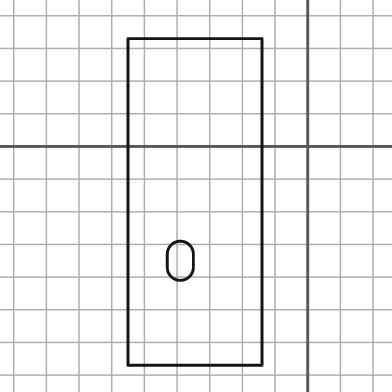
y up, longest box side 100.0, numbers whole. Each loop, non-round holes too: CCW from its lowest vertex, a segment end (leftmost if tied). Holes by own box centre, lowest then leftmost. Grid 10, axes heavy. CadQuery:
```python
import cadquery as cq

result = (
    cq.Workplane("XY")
    .moveTo(-55.0, -67.0)
    .lineTo(-14.0, -67.0)
    .lineTo(-14.0, 33.0)
    .lineTo(-55.0, 33.0)
    .close()
    .moveTo(-43.0, -37.0)
    .threePointArc((-39.0, -41.0), (-35.0, -37.0))
    .lineTo(-35.0, -33.0)
    .threePointArc((-39.0, -29.0), (-43.0, -33.0))
    .close()
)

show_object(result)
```